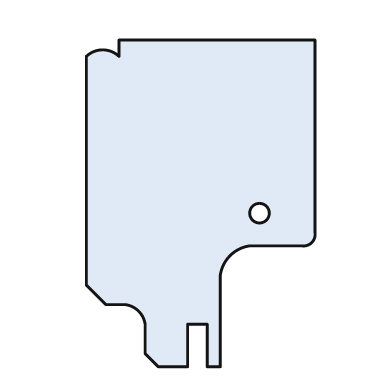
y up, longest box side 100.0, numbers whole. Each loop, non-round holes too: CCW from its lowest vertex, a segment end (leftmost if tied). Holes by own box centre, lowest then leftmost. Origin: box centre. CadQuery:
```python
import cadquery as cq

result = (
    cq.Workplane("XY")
    .moveTo(-13.0, -50.0)
    .lineTo(-4.0, -50.0)
    .lineTo(-4.0, -37.0)
    .lineTo(2.0, -37.0)
    .lineTo(2.0, -50.0)
    .lineTo(6.0, -50.0)
    .lineTo(6.0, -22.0)
    .threePointArc((9.0, -16.0), (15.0, -13.0))
    .lineTo(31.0, -13.0)
    .threePointArc((34.0, -12.0), (35.0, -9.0))
    .lineTo(35.0, 50.0)
    .lineTo(-25.0, 50.0)
    .lineTo(-25.0, 45.0)
    .threePointArc((-30.0, 47.0), (-35.0, 45.0))
    .lineTo(-35.0, -25.0)
    .lineTo(-29.0, -31.0)
    .lineTo(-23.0, -31.0)
    .threePointArc((-19.0, -33.0), (-17.0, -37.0))
    .lineTo(-17.0, -46.0)
    .close()
    .moveTo(18.0, -3.0)
    .circle(3.0)
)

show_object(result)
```